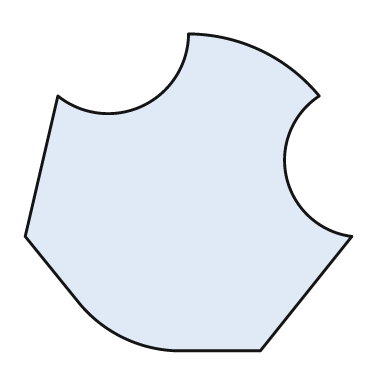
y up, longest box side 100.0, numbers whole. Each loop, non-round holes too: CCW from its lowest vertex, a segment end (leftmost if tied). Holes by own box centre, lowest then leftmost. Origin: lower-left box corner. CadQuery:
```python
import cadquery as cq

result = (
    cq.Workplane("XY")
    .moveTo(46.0, 0.0)
    .lineTo(72.0, 0.0)
    .lineTo(100.0, 35.0)
    .threePointArc((80.0, 53.0), (90.0, 78.0))
    .threePointArc((72.0, 92.0), (50.0, 97.0))
    .threePointArc((36.0, 75.0), (10.0, 78.0))
    .lineTo(0.0, 35.0)
    .lineTo(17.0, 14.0)
    .threePointArc((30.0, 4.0), (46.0, 0.0))
    .close()
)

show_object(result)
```